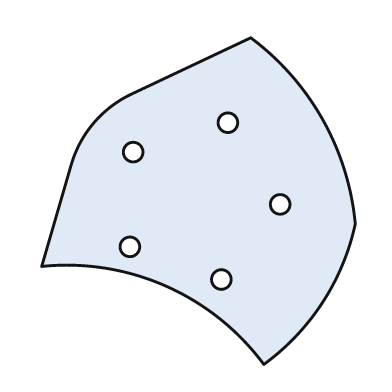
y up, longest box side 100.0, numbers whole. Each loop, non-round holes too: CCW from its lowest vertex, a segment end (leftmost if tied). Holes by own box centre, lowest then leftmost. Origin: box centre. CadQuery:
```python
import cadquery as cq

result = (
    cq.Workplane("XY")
    .moveTo(20.0, -50.0)
    .threePointArc((38.0, -31.0), (48.0, -7.0))
    .threePointArc((38.0, 25.0), (16.0, 50.0))
    .lineTo(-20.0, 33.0)
    .threePointArc((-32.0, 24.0), (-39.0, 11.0))
    .lineTo(-48.0, -20.0)
    .threePointArc((-10.0, -26.0), (20.0, -50.0))
    .close()
    .moveTo(7.0, -24.0)
    .circle(3.0)
    .moveTo(-21.0, -14.0)
    .circle(3.0)
    .moveTo(25.0, -1.0)
    .circle(3.0)
    .moveTo(-20.0, 15.0)
    .circle(3.0)
    .moveTo(9.0, 24.0)
    .circle(3.0)
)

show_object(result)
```